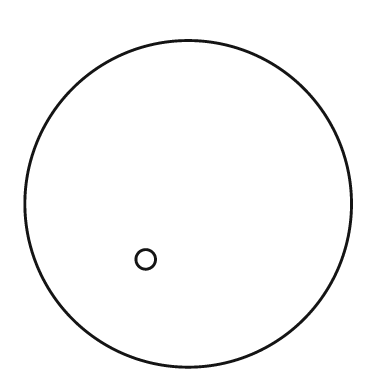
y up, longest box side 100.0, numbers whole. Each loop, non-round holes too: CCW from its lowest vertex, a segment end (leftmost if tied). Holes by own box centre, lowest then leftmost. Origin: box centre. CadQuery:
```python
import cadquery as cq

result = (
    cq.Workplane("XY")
    .moveTo(0.0, 0.0)
    .circle(50.0)
    .moveTo(-13.0, -17.0)
    .circle(3.0)
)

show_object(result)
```